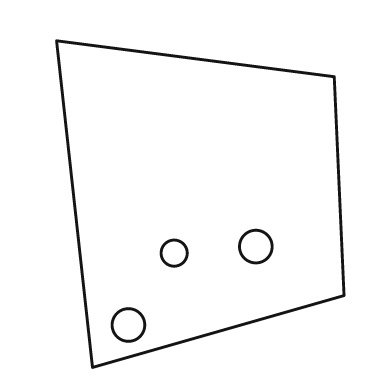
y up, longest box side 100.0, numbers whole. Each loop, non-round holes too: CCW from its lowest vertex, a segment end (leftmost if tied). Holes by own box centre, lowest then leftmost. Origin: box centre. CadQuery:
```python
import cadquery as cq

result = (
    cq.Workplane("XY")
    .moveTo(-33.0, -50.0)
    .lineTo(44.0, -28.0)
    .lineTo(41.0, 39.0)
    .lineTo(-44.0, 50.0)
    .close()
    .moveTo(-22.0, -37.0)
    .circle(5.0)
    .moveTo(-8.0, -15.0)
    .circle(4.0)
    .moveTo(17.0, -13.0)
    .circle(5.0)
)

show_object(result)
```